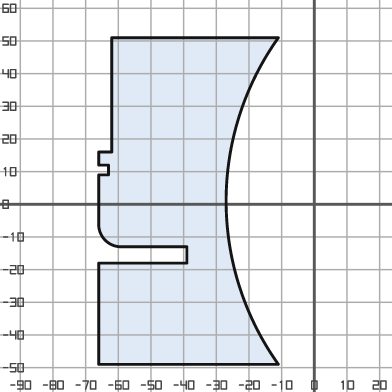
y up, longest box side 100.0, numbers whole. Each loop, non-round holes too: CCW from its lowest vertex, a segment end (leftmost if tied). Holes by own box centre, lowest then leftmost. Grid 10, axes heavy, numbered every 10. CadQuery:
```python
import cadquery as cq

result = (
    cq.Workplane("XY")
    .moveTo(-66.0, -49.0)
    .lineTo(-11.0, -49.0)
    .threePointArc((-27.0, 1.0), (-11.0, 51.0))
    .lineTo(-62.0, 51.0)
    .lineTo(-62.0, 16.0)
    .lineTo(-66.0, 16.0)
    .lineTo(-66.0, 12.0)
    .lineTo(-63.0, 12.0)
    .lineTo(-63.0, 9.0)
    .lineTo(-66.0, 9.0)
    .lineTo(-66.0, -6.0)
    .threePointArc((-64.0, -11.0), (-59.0, -13.0))
    .lineTo(-39.0, -13.0)
    .lineTo(-39.0, -18.0)
    .lineTo(-66.0, -18.0)
    .close()
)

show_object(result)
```